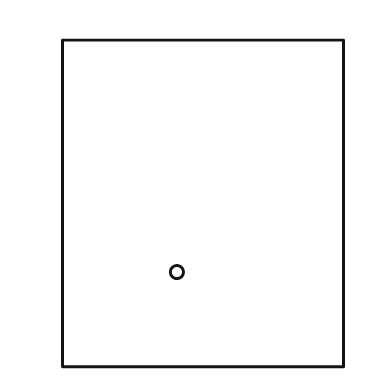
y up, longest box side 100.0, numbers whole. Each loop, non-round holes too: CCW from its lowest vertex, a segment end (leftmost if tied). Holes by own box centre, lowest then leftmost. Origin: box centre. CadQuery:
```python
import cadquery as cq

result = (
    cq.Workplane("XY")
    .moveTo(-43.0, -50.0)
    .lineTo(43.0, -50.0)
    .lineTo(43.0, 50.0)
    .lineTo(-43.0, 50.0)
    .close()
    .moveTo(-8.0, -21.0)
    .circle(2.0)
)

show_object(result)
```